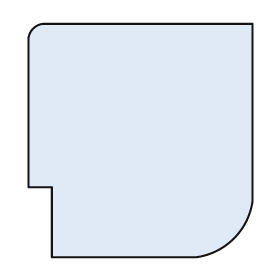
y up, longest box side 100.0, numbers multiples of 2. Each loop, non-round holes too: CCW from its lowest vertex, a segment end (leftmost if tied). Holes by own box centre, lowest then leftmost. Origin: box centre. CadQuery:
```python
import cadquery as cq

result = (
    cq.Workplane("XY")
    .moveTo(-38.0, -50.0)
    .lineTo(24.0, -50.0)
    .threePointArc((40.0, -42.0), (48.0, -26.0))
    .lineTo(48.0, 50.0)
    .lineTo(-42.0, 50.0)
    .threePointArc((-46.0, 48.0), (-48.0, 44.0))
    .lineTo(-48.0, -20.0)
    .lineTo(-38.0, -20.0)
    .close()
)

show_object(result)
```